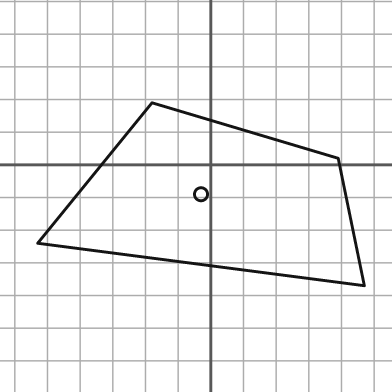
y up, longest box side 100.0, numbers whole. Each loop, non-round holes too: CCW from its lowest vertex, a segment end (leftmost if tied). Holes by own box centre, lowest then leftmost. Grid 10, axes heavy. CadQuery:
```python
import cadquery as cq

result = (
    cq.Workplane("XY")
    .moveTo(47.0, -37.0)
    .lineTo(39.0, 2.0)
    .lineTo(-18.0, 19.0)
    .lineTo(-53.0, -24.0)
    .close()
    .moveTo(-3.0, -9.0)
    .circle(2.0)
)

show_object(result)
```